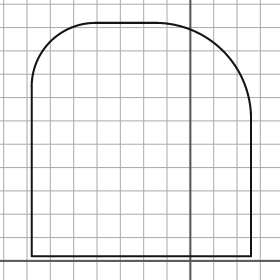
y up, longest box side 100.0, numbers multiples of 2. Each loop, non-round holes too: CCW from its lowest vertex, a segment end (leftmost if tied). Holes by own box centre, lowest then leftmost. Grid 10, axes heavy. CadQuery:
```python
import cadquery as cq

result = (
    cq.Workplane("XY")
    .moveTo(-68.0, 2.0)
    .lineTo(26.0, 2.0)
    .lineTo(26.0, 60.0)
    .threePointArc((14.0, 90.0), (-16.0, 102.0))
    .lineTo(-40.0, 102.0)
    .threePointArc((-60.0, 94.0), (-68.0, 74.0))
    .close()
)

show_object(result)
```